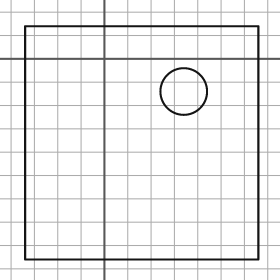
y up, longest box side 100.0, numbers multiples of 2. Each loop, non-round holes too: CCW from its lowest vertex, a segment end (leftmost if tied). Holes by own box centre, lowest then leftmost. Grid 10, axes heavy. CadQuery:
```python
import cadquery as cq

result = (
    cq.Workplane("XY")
    .moveTo(-34.0, -86.0)
    .lineTo(66.0, -86.0)
    .lineTo(66.0, 14.0)
    .lineTo(-34.0, 14.0)
    .close()
    .moveTo(34.0, -14.0)
    .circle(10.0)
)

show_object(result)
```